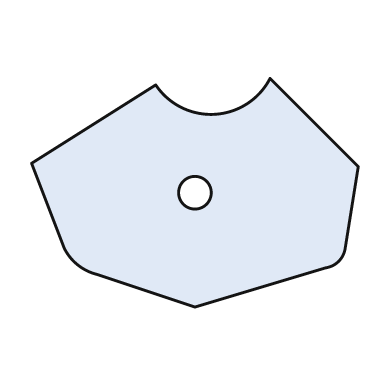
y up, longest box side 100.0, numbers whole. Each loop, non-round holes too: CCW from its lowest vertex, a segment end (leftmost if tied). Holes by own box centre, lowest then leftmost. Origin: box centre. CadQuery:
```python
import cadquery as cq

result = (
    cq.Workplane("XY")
    .moveTo(0.0, -35.0)
    .lineTo(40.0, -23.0)
    .threePointArc((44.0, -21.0), (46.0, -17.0))
    .lineTo(50.0, 8.0)
    .lineTo(23.0, 35.0)
    .threePointArc((6.0, 24.0), (-12.0, 33.0))
    .lineTo(-50.0, 9.0)
    .lineTo(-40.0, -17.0)
    .threePointArc((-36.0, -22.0), (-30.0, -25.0))
    .close()
    .moveTo(0.0, 0.0)
    .circle(5.0)
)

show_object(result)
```